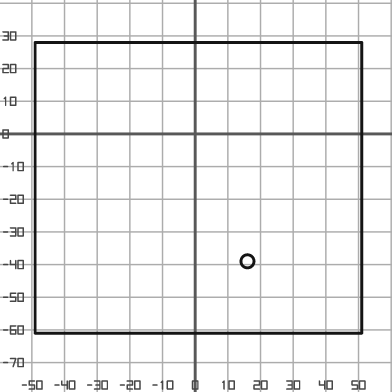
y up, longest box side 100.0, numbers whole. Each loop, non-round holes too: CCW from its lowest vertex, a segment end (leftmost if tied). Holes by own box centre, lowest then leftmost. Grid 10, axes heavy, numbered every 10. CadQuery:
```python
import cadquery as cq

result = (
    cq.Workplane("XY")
    .moveTo(-49.0, -61.0)
    .lineTo(51.0, -61.0)
    .lineTo(51.0, 28.0)
    .lineTo(-49.0, 28.0)
    .close()
    .moveTo(16.0, -39.0)
    .circle(2.0)
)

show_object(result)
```